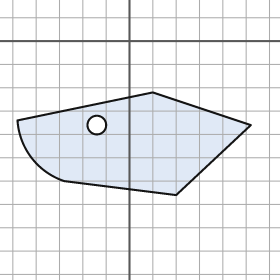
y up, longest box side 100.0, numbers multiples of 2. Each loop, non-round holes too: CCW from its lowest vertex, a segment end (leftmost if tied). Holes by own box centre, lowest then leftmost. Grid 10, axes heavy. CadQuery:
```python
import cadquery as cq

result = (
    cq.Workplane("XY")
    .moveTo(20.0, -66.0)
    .lineTo(52.0, -36.0)
    .lineTo(10.0, -22.0)
    .lineTo(-48.0, -34.0)
    .threePointArc((-42.0, -50.0), (-28.0, -60.0))
    .close()
    .moveTo(-14.0, -36.0)
    .circle(4.0)
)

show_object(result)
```